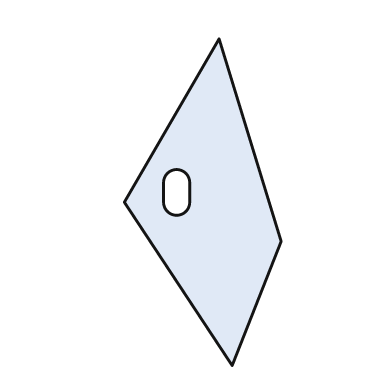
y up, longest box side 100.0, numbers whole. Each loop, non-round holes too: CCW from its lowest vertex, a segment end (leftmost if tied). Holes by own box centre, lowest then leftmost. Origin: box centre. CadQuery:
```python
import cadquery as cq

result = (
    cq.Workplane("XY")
    .moveTo(9.0, -50.0)
    .lineTo(24.0, -12.0)
    .lineTo(5.0, 50.0)
    .lineTo(-24.0, 0.0)
    .close()
    .moveTo(-12.0, 0.0)
    .threePointArc((-8.0, -4.0), (-4.0, 0.0))
    .lineTo(-4.0, 6.0)
    .threePointArc((-8.0, 10.0), (-12.0, 6.0))
    .close()
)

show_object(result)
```